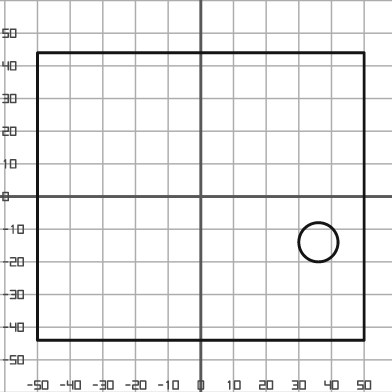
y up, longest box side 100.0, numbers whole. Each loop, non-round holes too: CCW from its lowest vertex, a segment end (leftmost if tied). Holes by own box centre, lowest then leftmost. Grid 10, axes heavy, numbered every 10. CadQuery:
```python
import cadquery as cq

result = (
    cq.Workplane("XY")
    .moveTo(-50.0, -44.0)
    .lineTo(50.0, -44.0)
    .lineTo(50.0, 44.0)
    .lineTo(-50.0, 44.0)
    .close()
    .moveTo(36.0, -14.0)
    .circle(6.0)
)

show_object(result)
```